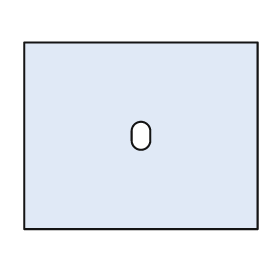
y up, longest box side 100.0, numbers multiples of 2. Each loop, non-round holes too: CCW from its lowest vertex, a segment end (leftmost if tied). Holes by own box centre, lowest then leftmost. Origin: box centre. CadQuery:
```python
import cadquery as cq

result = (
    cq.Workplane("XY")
    .moveTo(-50.0, -40.0)
    .lineTo(50.0, -40.0)
    .lineTo(50.0, 40.0)
    .lineTo(-50.0, 40.0)
    .close()
    .moveTo(-4.0, -2.0)
    .threePointArc((0.0, -6.0), (4.0, -2.0))
    .lineTo(4.0, 2.0)
    .threePointArc((0.0, 6.0), (-4.0, 2.0))
    .close()
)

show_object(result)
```